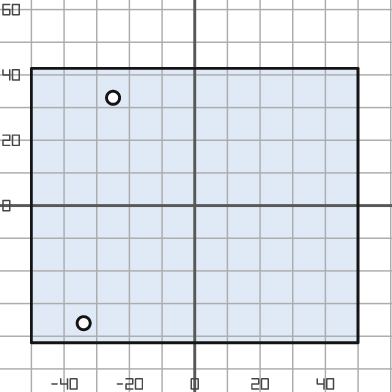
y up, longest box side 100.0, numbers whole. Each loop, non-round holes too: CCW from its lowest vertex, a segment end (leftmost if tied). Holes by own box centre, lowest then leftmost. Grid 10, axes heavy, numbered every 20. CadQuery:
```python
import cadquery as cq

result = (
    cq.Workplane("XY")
    .moveTo(-50.0, -42.0)
    .lineTo(50.0, -42.0)
    .lineTo(50.0, 42.0)
    .lineTo(-50.0, 42.0)
    .close()
    .moveTo(-34.0, -36.0)
    .circle(2.0)
    .moveTo(-25.0, 33.0)
    .circle(2.0)
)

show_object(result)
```